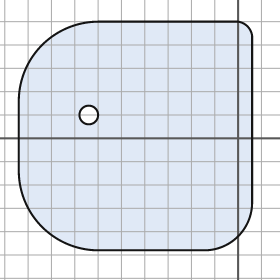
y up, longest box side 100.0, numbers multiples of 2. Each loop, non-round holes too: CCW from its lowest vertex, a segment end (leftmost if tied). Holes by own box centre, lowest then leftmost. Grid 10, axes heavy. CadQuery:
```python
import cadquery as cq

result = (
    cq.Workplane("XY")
    .moveTo(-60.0, -48.0)
    .lineTo(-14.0, -48.0)
    .threePointArc((0.0, -42.0), (6.0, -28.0))
    .lineTo(6.0, 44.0)
    .threePointArc((4.0, 48.0), (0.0, 50.0))
    .lineTo(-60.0, 50.0)
    .threePointArc((-84.0, 40.0), (-94.0, 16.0))
    .lineTo(-94.0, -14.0)
    .threePointArc((-84.0, -38.0), (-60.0, -48.0))
    .close()
    .moveTo(-64.0, 10.0)
    .circle(4.0)
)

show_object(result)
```